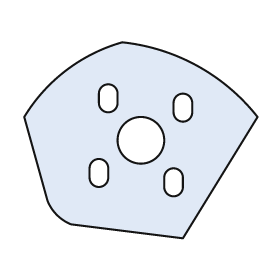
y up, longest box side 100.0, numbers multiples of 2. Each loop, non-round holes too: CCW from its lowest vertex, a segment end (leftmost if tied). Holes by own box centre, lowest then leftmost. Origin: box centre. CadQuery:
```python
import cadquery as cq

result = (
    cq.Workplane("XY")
    .moveTo(18.0, -42.0)
    .lineTo(50.0, 10.0)
    .threePointArc((24.0, 32.0), (-8.0, 42.0))
    .threePointArc((-32.0, 30.0), (-50.0, 10.0))
    .lineTo(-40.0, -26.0)
    .threePointArc((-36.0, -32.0), (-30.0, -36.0))
    .close()
    .moveTo(10.0, -20.0)
    .threePointArc((14.0, -24.0), (18.0, -20.0))
    .lineTo(18.0, -16.0)
    .threePointArc((14.0, -12.0), (10.0, -16.0))
    .close()
    .moveTo(-22.0, -16.0)
    .threePointArc((-18.0, -20.0), (-14.0, -16.0))
    .lineTo(-14.0, -12.0)
    .threePointArc((-18.0, -8.0), (-22.0, -12.0))
    .close()
    .moveTo(0.0, 0.0)
    .circle(10.0)
    .moveTo(14.0, 12.0)
    .threePointArc((18.0, 8.0), (22.0, 12.0))
    .lineTo(22.0, 16.0)
    .threePointArc((18.0, 20.0), (14.0, 16.0))
    .close()
    .moveTo(-18.0, 16.0)
    .threePointArc((-14.0, 12.0), (-10.0, 16.0))
    .lineTo(-10.0, 20.0)
    .threePointArc((-14.0, 24.0), (-18.0, 20.0))
    .close()
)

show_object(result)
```